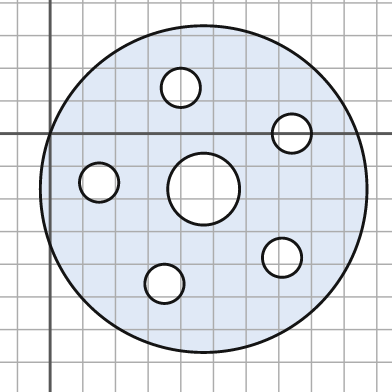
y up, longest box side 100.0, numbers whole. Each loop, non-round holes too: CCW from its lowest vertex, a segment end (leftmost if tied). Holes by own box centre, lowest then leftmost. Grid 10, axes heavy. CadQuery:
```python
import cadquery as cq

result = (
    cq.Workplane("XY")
    .moveTo(47.0, -17.0)
    .circle(50.0)
    .moveTo(35.0, -46.0)
    .circle(6.0)
    .moveTo(71.0, -38.0)
    .circle(6.0)
    .moveTo(47.0, -17.0)
    .circle(11.0)
    .moveTo(15.0, -15.0)
    .circle(6.0)
    .moveTo(74.0, 0.0)
    .circle(6.0)
    .moveTo(40.0, 14.0)
    .circle(6.0)
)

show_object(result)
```